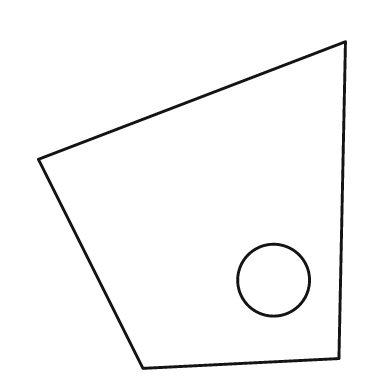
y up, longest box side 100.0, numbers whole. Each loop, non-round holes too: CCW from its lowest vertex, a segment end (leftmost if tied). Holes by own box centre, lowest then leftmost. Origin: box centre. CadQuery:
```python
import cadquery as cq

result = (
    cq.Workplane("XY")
    .moveTo(-15.0, -50.0)
    .lineTo(45.0, -47.0)
    .lineTo(47.0, 50.0)
    .lineTo(-47.0, 14.0)
    .close()
    .moveTo(25.0, -23.0)
    .circle(11.0)
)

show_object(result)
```